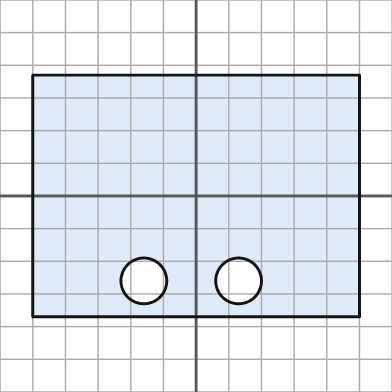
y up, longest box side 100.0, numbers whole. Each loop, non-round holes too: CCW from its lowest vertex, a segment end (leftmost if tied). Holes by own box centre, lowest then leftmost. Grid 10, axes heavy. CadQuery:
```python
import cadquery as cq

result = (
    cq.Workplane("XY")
    .moveTo(-50.0, -37.0)
    .lineTo(50.0, -37.0)
    .lineTo(50.0, 37.0)
    .lineTo(-50.0, 37.0)
    .close()
    .moveTo(-16.0, -26.0)
    .circle(7.0)
    .moveTo(13.0, -26.0)
    .circle(7.0)
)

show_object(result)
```